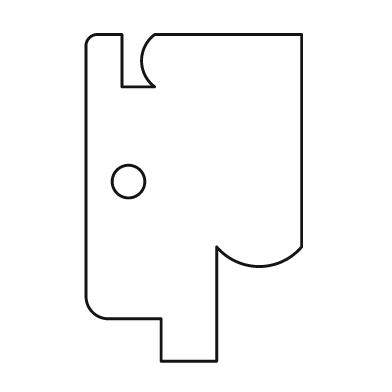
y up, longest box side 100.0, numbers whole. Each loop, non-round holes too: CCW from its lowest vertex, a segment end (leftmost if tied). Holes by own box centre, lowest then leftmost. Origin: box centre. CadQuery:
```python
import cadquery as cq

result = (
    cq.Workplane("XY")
    .moveTo(-10.0, -50.0)
    .lineTo(7.0, -50.0)
    .lineTo(7.0, -15.0)
    .threePointArc((20.0, -21.0), (33.0, -15.0))
    .lineTo(33.0, 50.0)
    .lineTo(-12.0, 50.0)
    .threePointArc((-16.0, 42.0), (-12.0, 34.0))
    .lineTo(-22.0, 34.0)
    .lineTo(-22.0, 50.0)
    .lineTo(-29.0, 50.0)
    .threePointArc((-32.0, 49.0), (-33.0, 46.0))
    .lineTo(-33.0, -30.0)
    .threePointArc((-31.0, -35.0), (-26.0, -37.0))
    .lineTo(-10.0, -37.0)
    .close()
    .moveTo(-20.0, 5.0)
    .circle(5.0)
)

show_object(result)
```